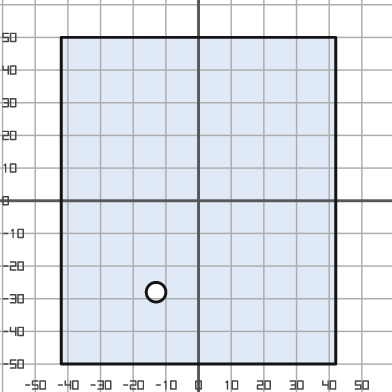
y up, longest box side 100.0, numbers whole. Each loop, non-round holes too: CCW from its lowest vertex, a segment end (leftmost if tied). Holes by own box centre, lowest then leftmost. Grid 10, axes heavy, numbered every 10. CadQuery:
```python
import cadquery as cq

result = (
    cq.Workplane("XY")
    .moveTo(-42.0, -50.0)
    .lineTo(42.0, -50.0)
    .lineTo(42.0, 50.0)
    .lineTo(-42.0, 50.0)
    .close()
    .moveTo(-13.0, -28.0)
    .circle(3.0)
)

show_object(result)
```